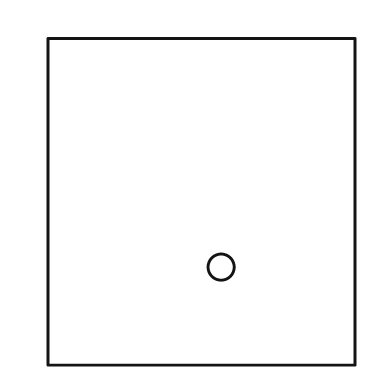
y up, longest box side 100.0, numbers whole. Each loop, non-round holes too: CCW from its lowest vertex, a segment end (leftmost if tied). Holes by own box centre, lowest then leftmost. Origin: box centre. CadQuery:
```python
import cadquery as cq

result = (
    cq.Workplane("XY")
    .moveTo(-47.0, -50.0)
    .lineTo(47.0, -50.0)
    .lineTo(47.0, 50.0)
    .lineTo(-47.0, 50.0)
    .close()
    .moveTo(6.0, -20.0)
    .circle(4.0)
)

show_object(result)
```